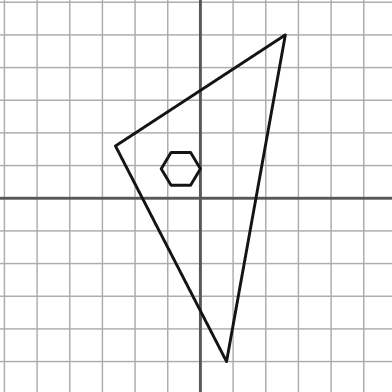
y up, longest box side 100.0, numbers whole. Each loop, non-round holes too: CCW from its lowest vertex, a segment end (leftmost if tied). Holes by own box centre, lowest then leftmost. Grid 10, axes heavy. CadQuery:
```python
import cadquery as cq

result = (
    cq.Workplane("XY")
    .moveTo(8.0, -50.0)
    .lineTo(26.0, 50.0)
    .lineTo(-26.0, 16.0)
    .close()
    .moveTo(-9.0, 4.0)
    .lineTo(-3.0, 4.0)
    .lineTo(0.0, 9.0)
    .lineTo(-3.0, 14.0)
    .lineTo(-9.0, 14.0)
    .lineTo(-12.0, 9.0)
    .close()
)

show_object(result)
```